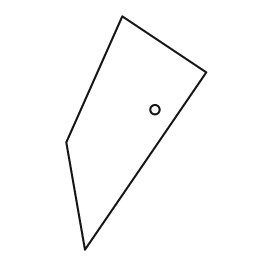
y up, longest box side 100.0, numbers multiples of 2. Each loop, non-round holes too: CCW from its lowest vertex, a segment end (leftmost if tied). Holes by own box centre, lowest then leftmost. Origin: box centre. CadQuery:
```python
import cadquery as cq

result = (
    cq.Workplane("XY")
    .moveTo(-22.0, -50.0)
    .lineTo(30.0, 26.0)
    .lineTo(-6.0, 50.0)
    .lineTo(-30.0, -4.0)
    .close()
    .moveTo(8.0, 10.0)
    .circle(2.0)
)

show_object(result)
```